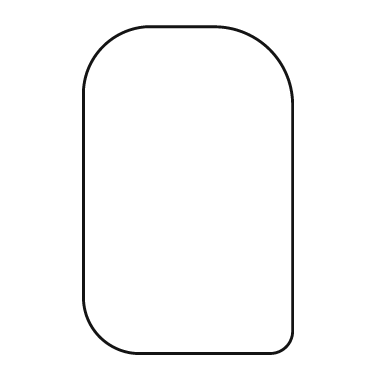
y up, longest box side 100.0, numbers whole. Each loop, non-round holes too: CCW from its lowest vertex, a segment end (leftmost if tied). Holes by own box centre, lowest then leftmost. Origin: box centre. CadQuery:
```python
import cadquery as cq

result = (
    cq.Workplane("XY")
    .moveTo(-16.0, -50.0)
    .lineTo(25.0, -50.0)
    .threePointArc((30.0, -48.0), (32.0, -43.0))
    .lineTo(32.0, 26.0)
    .threePointArc((25.0, 43.0), (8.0, 50.0))
    .lineTo(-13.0, 50.0)
    .threePointArc((-26.0, 44.0), (-32.0, 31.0))
    .lineTo(-32.0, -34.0)
    .threePointArc((-27.0, -45.0), (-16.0, -50.0))
    .close()
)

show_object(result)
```